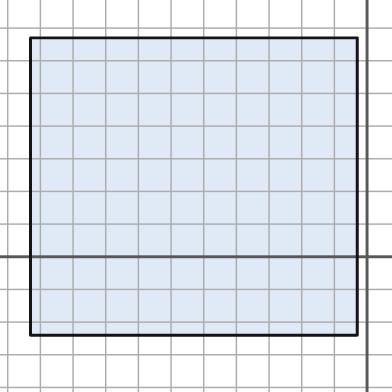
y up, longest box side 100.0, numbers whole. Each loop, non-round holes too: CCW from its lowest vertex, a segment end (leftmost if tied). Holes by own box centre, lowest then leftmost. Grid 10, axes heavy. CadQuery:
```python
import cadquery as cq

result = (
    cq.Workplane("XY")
    .moveTo(-103.0, -24.0)
    .lineTo(-3.0, -24.0)
    .lineTo(-3.0, 67.0)
    .lineTo(-103.0, 67.0)
    .close()
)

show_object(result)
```